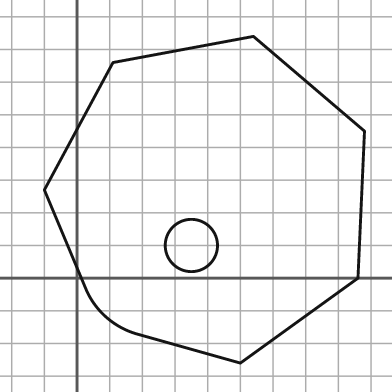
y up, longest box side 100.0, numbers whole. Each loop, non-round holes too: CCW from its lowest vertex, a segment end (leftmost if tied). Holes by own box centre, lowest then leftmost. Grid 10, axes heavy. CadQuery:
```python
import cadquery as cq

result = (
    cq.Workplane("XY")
    .moveTo(50.0, -26.0)
    .lineTo(86.0, 0.0)
    .lineTo(88.0, 45.0)
    .lineTo(54.0, 74.0)
    .lineTo(11.0, 66.0)
    .lineTo(-10.0, 27.0)
    .lineTo(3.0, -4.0)
    .threePointArc((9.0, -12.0), (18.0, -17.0))
    .close()
    .moveTo(35.0, 10.0)
    .circle(8.0)
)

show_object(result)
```